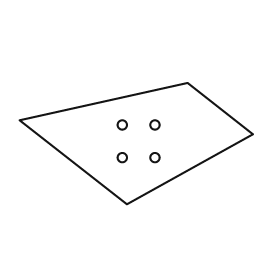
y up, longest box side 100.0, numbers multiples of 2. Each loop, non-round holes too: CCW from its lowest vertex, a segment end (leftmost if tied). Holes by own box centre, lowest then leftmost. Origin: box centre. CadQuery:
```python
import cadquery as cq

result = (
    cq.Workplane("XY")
    .moveTo(-4.0, -26.0)
    .lineTo(50.0, 4.0)
    .lineTo(22.0, 26.0)
    .lineTo(-50.0, 10.0)
    .close()
    .moveTo(-6.0, -6.0)
    .circle(2.0)
    .moveTo(8.0, -6.0)
    .circle(2.0)
    .moveTo(-6.0, 8.0)
    .circle(2.0)
    .moveTo(8.0, 8.0)
    .circle(2.0)
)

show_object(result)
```